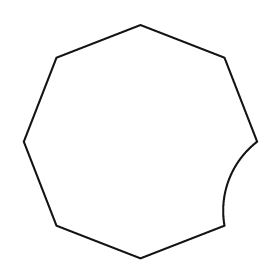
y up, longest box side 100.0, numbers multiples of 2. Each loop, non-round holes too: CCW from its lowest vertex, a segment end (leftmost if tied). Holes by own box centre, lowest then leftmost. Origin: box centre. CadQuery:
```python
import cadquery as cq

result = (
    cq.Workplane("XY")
    .moveTo(0.0, -50.0)
    .lineTo(36.0, -36.0)
    .threePointArc((38.0, -16.0), (50.0, 0.0))
    .lineTo(36.0, 36.0)
    .lineTo(0.0, 50.0)
    .lineTo(-36.0, 36.0)
    .lineTo(-50.0, 0.0)
    .lineTo(-36.0, -36.0)
    .close()
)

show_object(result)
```